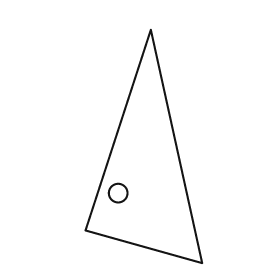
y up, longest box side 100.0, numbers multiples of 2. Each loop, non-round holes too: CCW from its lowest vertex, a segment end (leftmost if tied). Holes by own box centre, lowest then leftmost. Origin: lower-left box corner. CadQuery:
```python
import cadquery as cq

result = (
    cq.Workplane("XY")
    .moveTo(50.0, 0.0)
    .lineTo(28.0, 100.0)
    .lineTo(0.0, 14.0)
    .close()
    .moveTo(14.0, 30.0)
    .circle(4.0)
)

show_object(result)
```